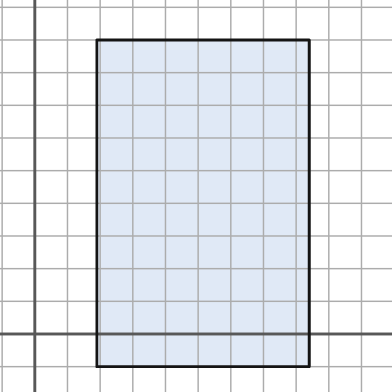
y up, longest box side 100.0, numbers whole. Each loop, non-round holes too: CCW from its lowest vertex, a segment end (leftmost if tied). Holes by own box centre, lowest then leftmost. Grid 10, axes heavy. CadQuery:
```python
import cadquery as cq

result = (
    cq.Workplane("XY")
    .moveTo(19.0, -10.0)
    .lineTo(84.0, -10.0)
    .lineTo(84.0, 90.0)
    .lineTo(19.0, 90.0)
    .close()
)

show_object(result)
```